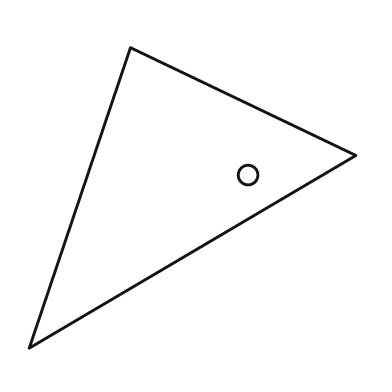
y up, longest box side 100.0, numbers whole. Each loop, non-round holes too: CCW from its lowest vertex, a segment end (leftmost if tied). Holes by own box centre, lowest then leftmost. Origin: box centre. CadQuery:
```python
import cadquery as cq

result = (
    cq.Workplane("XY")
    .moveTo(-50.0, -46.0)
    .lineTo(50.0, 13.0)
    .lineTo(-19.0, 46.0)
    .close()
    .moveTo(17.0, 7.0)
    .circle(3.0)
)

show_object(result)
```